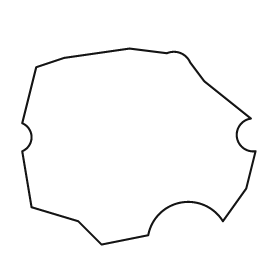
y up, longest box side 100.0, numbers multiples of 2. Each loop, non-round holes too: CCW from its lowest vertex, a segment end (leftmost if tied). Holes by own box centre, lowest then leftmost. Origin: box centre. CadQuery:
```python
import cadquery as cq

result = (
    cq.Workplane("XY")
    .moveTo(-16.0, -42.0)
    .lineTo(4.0, -38.0)
    .threePointArc((18.0, -24.0), (36.0, -32.0))
    .lineTo(46.0, -18.0)
    .lineTo(50.0, -2.0)
    .threePointArc((42.0, 4.0), (48.0, 12.0))
    .lineTo(28.0, 28.0)
    .lineTo(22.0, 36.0)
    .threePointArc((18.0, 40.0), (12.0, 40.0))
    .lineTo(-4.0, 42.0)
    .lineTo(-32.0, 38.0)
    .lineTo(-44.0, 34.0)
    .lineTo(-50.0, 10.0)
    .threePointArc((-46.0, 4.0), (-50.0, -2.0))
    .lineTo(-46.0, -26.0)
    .lineTo(-26.0, -32.0)
    .close()
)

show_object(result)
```